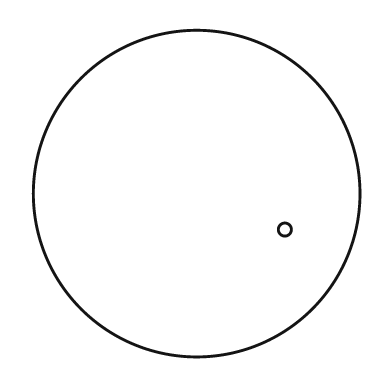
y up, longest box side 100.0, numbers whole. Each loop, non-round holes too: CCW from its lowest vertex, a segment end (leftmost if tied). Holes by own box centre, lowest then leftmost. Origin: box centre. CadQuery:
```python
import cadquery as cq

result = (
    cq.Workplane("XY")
    .moveTo(0.0, 0.0)
    .circle(50.0)
    .moveTo(27.0, -11.0)
    .circle(2.0)
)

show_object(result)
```